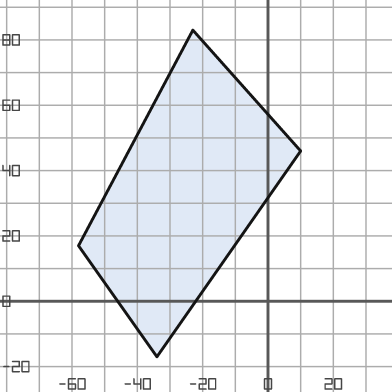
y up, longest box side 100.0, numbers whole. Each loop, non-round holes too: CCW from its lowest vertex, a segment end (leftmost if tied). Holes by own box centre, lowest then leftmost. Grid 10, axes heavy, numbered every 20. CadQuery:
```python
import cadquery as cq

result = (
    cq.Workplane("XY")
    .moveTo(-34.0, -17.0)
    .lineTo(10.0, 46.0)
    .lineTo(-23.0, 83.0)
    .lineTo(-58.0, 17.0)
    .close()
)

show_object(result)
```